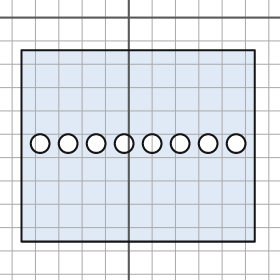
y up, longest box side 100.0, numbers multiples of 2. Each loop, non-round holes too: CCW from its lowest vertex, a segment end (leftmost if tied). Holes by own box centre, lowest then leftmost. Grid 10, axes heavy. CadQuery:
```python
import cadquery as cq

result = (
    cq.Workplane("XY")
    .moveTo(-46.0, -96.0)
    .lineTo(54.0, -96.0)
    .lineTo(54.0, -14.0)
    .lineTo(-46.0, -14.0)
    .close()
    .moveTo(-38.0, -54.0)
    .circle(4.0)
    .moveTo(-26.0, -54.0)
    .circle(4.0)
    .moveTo(-14.0, -54.0)
    .circle(4.0)
    .moveTo(-2.0, -54.0)
    .circle(4.0)
    .moveTo(10.0, -54.0)
    .circle(4.0)
    .moveTo(22.0, -54.0)
    .circle(4.0)
    .moveTo(34.0, -54.0)
    .circle(4.0)
    .moveTo(46.0, -54.0)
    .circle(4.0)
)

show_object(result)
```